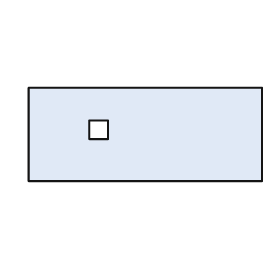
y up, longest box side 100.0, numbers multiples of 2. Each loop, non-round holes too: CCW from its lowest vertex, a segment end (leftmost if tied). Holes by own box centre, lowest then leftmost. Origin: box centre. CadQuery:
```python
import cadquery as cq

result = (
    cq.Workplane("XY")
    .moveTo(-50.0, -20.0)
    .lineTo(50.0, -20.0)
    .lineTo(50.0, 20.0)
    .lineTo(-50.0, 20.0)
    .close()
    .moveTo(-24.0, -2.0)
    .lineTo(-16.0, -2.0)
    .lineTo(-16.0, 6.0)
    .lineTo(-24.0, 6.0)
    .close()
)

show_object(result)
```